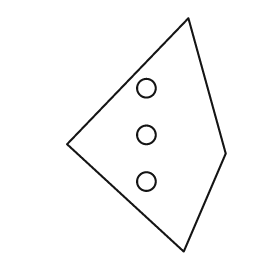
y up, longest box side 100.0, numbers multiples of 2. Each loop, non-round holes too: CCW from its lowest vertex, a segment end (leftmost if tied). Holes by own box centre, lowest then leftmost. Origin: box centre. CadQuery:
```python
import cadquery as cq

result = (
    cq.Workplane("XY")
    .moveTo(16.0, -50.0)
    .lineTo(34.0, -8.0)
    .lineTo(18.0, 50.0)
    .lineTo(-34.0, -4.0)
    .close()
    .moveTo(0.0, -20.0)
    .circle(4.0)
    .moveTo(0.0, 0.0)
    .circle(4.0)
    .moveTo(0.0, 20.0)
    .circle(4.0)
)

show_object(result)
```